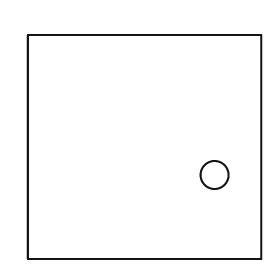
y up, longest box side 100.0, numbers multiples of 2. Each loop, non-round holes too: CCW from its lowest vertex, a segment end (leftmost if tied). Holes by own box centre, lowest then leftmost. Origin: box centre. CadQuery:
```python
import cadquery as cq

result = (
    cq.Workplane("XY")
    .moveTo(-50.0, -48.0)
    .lineTo(50.0, -48.0)
    .lineTo(50.0, 48.0)
    .lineTo(-50.0, 48.0)
    .close()
    .moveTo(30.0, -12.0)
    .circle(6.0)
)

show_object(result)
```